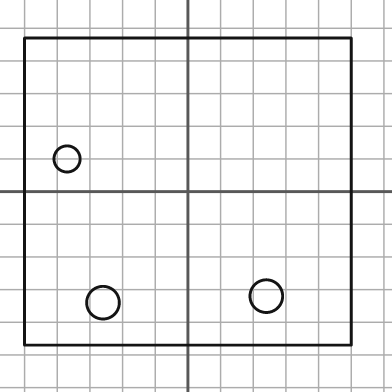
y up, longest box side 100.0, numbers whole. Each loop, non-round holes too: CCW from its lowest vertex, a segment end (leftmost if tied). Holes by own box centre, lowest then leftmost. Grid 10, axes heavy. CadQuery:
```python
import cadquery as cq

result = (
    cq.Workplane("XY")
    .moveTo(-50.0, -47.0)
    .lineTo(50.0, -47.0)
    .lineTo(50.0, 47.0)
    .lineTo(-50.0, 47.0)
    .close()
    .moveTo(-26.0, -34.0)
    .circle(5.0)
    .moveTo(24.0, -32.0)
    .circle(5.0)
    .moveTo(-37.0, 10.0)
    .circle(4.0)
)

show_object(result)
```